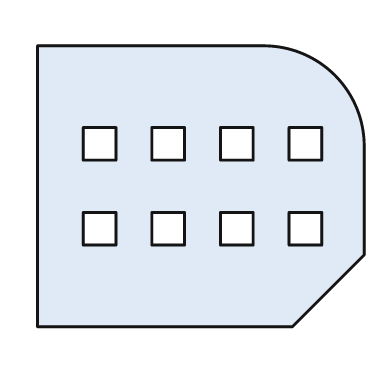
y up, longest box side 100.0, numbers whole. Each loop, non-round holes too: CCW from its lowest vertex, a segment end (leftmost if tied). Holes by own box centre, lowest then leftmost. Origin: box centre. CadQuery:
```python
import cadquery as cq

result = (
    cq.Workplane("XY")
    .moveTo(-50.0, -43.0)
    .lineTo(28.0, -43.0)
    .lineTo(50.0, -21.0)
    .lineTo(50.0, 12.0)
    .threePointArc((41.0, 34.0), (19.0, 43.0))
    .lineTo(-50.0, 43.0)
    .close()
    .moveTo(-36.0, -18.0)
    .lineTo(-26.0, -18.0)
    .lineTo(-26.0, -8.0)
    .lineTo(-36.0, -8.0)
    .close()
    .moveTo(-15.0, -18.0)
    .lineTo(-5.0, -18.0)
    .lineTo(-5.0, -8.0)
    .lineTo(-15.0, -8.0)
    .close()
    .moveTo(6.0, -18.0)
    .lineTo(16.0, -18.0)
    .lineTo(16.0, -8.0)
    .lineTo(6.0, -8.0)
    .close()
    .moveTo(27.0, -18.0)
    .lineTo(37.0, -18.0)
    .lineTo(37.0, -8.0)
    .lineTo(27.0, -8.0)
    .close()
    .moveTo(-36.0, 8.0)
    .lineTo(-26.0, 8.0)
    .lineTo(-26.0, 18.0)
    .lineTo(-36.0, 18.0)
    .close()
    .moveTo(-15.0, 8.0)
    .lineTo(-5.0, 8.0)
    .lineTo(-5.0, 18.0)
    .lineTo(-15.0, 18.0)
    .close()
    .moveTo(6.0, 8.0)
    .lineTo(16.0, 8.0)
    .lineTo(16.0, 18.0)
    .lineTo(6.0, 18.0)
    .close()
    .moveTo(27.0, 8.0)
    .lineTo(37.0, 8.0)
    .lineTo(37.0, 18.0)
    .lineTo(27.0, 18.0)
    .close()
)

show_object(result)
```